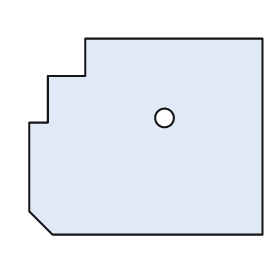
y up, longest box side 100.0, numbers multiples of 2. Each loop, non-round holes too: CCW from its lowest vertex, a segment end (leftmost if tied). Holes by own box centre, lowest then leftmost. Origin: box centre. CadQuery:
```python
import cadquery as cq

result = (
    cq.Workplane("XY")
    .moveTo(-40.0, -42.0)
    .lineTo(50.0, -42.0)
    .lineTo(50.0, 42.0)
    .lineTo(-26.0, 42.0)
    .lineTo(-26.0, 26.0)
    .lineTo(-42.0, 26.0)
    .lineTo(-42.0, 6.0)
    .lineTo(-50.0, 6.0)
    .lineTo(-50.0, -32.0)
    .close()
    .moveTo(8.0, 8.0)
    .circle(4.0)
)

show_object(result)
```